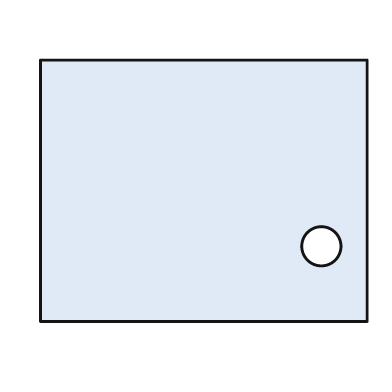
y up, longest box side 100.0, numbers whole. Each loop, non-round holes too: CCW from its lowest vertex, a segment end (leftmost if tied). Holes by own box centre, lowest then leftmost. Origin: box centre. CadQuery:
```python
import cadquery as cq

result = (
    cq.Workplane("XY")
    .moveTo(-50.0, -40.0)
    .lineTo(50.0, -40.0)
    .lineTo(50.0, 40.0)
    .lineTo(-50.0, 40.0)
    .close()
    .moveTo(36.0, -17.0)
    .circle(6.0)
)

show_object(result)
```